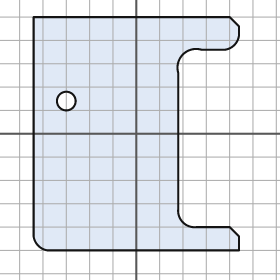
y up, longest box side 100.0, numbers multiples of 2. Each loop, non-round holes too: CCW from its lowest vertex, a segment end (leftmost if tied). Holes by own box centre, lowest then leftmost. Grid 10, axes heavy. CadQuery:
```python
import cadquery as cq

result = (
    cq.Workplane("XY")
    .moveTo(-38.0, -50.0)
    .lineTo(44.0, -50.0)
    .lineTo(44.0, -44.0)
    .lineTo(40.0, -40.0)
    .lineTo(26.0, -40.0)
    .threePointArc((20.0, -38.0), (18.0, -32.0))
    .lineTo(18.0, 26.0)
    .threePointArc((20.0, 34.0), (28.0, 36.0))
    .lineTo(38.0, 36.0)
    .threePointArc((42.0, 38.0), (44.0, 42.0))
    .lineTo(44.0, 46.0)
    .lineTo(40.0, 50.0)
    .lineTo(-44.0, 50.0)
    .lineTo(-44.0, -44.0)
    .threePointArc((-42.0, -48.0), (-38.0, -50.0))
    .close()
    .moveTo(-30.0, 14.0)
    .circle(4.0)
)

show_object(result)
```